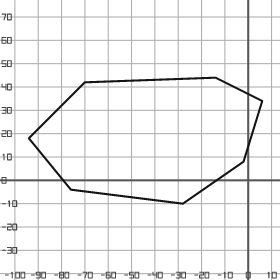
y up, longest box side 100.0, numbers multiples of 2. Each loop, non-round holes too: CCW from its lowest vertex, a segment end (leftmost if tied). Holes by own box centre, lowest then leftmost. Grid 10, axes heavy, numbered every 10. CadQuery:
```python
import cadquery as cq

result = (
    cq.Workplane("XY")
    .moveTo(-28.0, -10.0)
    .lineTo(-2.0, 8.0)
    .lineTo(6.0, 34.0)
    .lineTo(-14.0, 44.0)
    .lineTo(-70.0, 42.0)
    .lineTo(-94.0, 18.0)
    .lineTo(-76.0, -4.0)
    .close()
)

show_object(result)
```